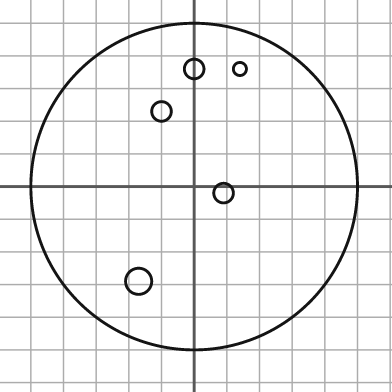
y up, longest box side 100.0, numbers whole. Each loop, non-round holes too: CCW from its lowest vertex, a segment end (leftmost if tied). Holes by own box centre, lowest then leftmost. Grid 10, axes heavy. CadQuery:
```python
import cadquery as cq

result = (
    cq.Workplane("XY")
    .moveTo(0.0, 0.0)
    .circle(50.0)
    .moveTo(-17.0, -29.0)
    .circle(4.0)
    .moveTo(9.0, -2.0)
    .circle(3.0)
    .moveTo(-10.0, 23.0)
    .circle(3.0)
    .moveTo(0.0, 36.0)
    .circle(3.0)
    .moveTo(14.0, 36.0)
    .circle(2.0)
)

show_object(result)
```